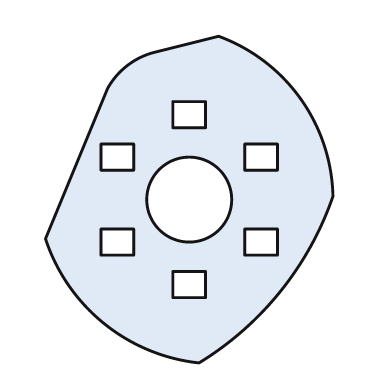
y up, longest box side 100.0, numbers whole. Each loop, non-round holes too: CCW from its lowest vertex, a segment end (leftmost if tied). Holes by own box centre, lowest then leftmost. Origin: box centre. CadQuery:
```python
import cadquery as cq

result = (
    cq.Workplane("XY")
    .moveTo(3.0, -50.0)
    .threePointArc((28.0, -28.0), (44.0, 1.0))
    .threePointArc((34.0, 31.0), (9.0, 50.0))
    .lineTo(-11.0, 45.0)
    .threePointArc((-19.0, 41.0), (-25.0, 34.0))
    .lineTo(-44.0, -12.0)
    .threePointArc((-26.0, -38.0), (3.0, -50.0))
    .close()
    .moveTo(-5.0, -30.0)
    .lineTo(5.0, -30.0)
    .lineTo(5.0, -22.0)
    .lineTo(-5.0, -22.0)
    .close()
    .moveTo(-27.0, -17.0)
    .lineTo(-17.0, -17.0)
    .lineTo(-17.0, -9.0)
    .lineTo(-27.0, -9.0)
    .close()
    .moveTo(17.0, -17.0)
    .lineTo(27.0, -17.0)
    .lineTo(27.0, -9.0)
    .lineTo(17.0, -9.0)
    .close()
    .moveTo(0.0, 0.0)
    .circle(13.0)
    .moveTo(-27.0, 9.0)
    .lineTo(-17.0, 9.0)
    .lineTo(-17.0, 17.0)
    .lineTo(-27.0, 17.0)
    .close()
    .moveTo(17.0, 9.0)
    .lineTo(27.0, 9.0)
    .lineTo(27.0, 17.0)
    .lineTo(17.0, 17.0)
    .close()
    .moveTo(-5.0, 22.0)
    .lineTo(5.0, 22.0)
    .lineTo(5.0, 30.0)
    .lineTo(-5.0, 30.0)
    .close()
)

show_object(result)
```